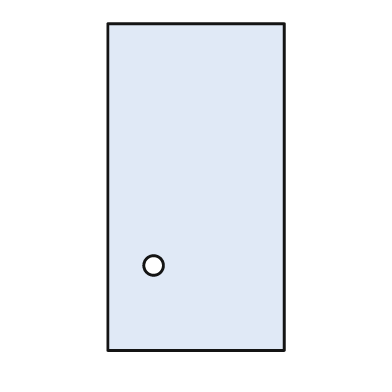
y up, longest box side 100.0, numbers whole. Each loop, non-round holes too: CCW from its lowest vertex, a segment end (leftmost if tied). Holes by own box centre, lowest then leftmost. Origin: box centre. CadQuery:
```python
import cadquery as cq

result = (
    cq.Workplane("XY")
    .moveTo(-27.0, -50.0)
    .lineTo(27.0, -50.0)
    .lineTo(27.0, 50.0)
    .lineTo(-27.0, 50.0)
    .close()
    .moveTo(-13.0, -24.0)
    .circle(3.0)
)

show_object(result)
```